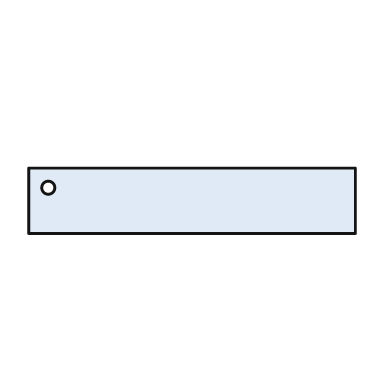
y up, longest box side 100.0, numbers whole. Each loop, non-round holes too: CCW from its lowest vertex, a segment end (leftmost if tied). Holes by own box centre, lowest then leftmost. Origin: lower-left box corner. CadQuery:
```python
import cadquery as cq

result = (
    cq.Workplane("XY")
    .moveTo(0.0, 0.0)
    .lineTo(100.0, 0.0)
    .lineTo(100.0, 20.0)
    .lineTo(0.0, 20.0)
    .close()
    .moveTo(6.0, 14.0)
    .circle(2.0)
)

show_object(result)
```